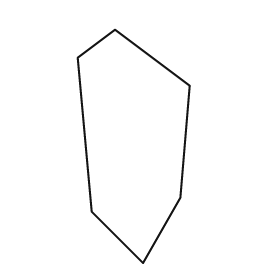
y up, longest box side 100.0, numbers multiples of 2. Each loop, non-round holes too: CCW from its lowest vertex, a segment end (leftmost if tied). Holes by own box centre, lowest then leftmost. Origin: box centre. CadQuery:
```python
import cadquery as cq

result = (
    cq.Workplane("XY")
    .moveTo(4.0, -50.0)
    .lineTo(20.0, -22.0)
    .lineTo(24.0, 26.0)
    .lineTo(-8.0, 50.0)
    .lineTo(-24.0, 38.0)
    .lineTo(-18.0, -28.0)
    .close()
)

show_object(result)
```